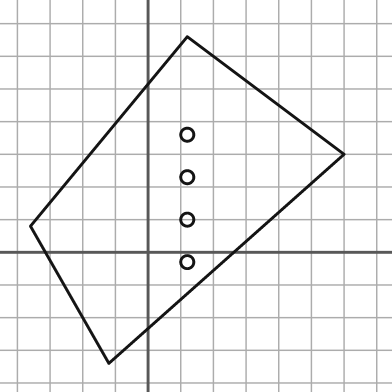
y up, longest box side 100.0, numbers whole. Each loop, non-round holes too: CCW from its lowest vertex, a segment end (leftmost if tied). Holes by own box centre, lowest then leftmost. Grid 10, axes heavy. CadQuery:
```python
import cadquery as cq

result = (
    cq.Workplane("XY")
    .moveTo(-12.0, -34.0)
    .lineTo(60.0, 30.0)
    .lineTo(12.0, 66.0)
    .lineTo(-36.0, 8.0)
    .close()
    .moveTo(12.0, -3.0)
    .circle(2.0)
    .moveTo(12.0, 10.0)
    .circle(2.0)
    .moveTo(12.0, 23.0)
    .circle(2.0)
    .moveTo(12.0, 36.0)
    .circle(2.0)
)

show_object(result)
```